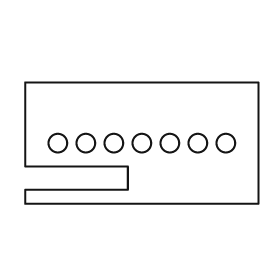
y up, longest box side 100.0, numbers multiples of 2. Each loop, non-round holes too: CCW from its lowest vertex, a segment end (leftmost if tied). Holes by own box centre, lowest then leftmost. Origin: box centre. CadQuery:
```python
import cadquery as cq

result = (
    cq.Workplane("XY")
    .moveTo(-50.0, -26.0)
    .lineTo(50.0, -26.0)
    .lineTo(50.0, 26.0)
    .lineTo(-50.0, 26.0)
    .lineTo(-50.0, -10.0)
    .lineTo(-6.0, -10.0)
    .lineTo(-6.0, -20.0)
    .lineTo(-50.0, -20.0)
    .close()
    .moveTo(-36.0, 0.0)
    .circle(4.0)
    .moveTo(-24.0, 0.0)
    .circle(4.0)
    .moveTo(-12.0, 0.0)
    .circle(4.0)
    .moveTo(0.0, 0.0)
    .circle(4.0)
    .moveTo(12.0, 0.0)
    .circle(4.0)
    .moveTo(24.0, 0.0)
    .circle(4.0)
    .moveTo(36.0, 0.0)
    .circle(4.0)
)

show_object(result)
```